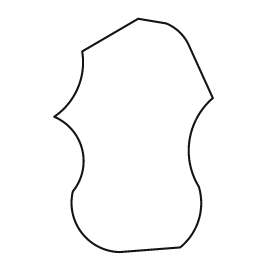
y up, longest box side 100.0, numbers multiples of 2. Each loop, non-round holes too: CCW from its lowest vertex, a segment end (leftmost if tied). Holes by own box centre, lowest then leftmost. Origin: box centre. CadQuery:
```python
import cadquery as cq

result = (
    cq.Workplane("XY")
    .moveTo(-6.0, -50.0)
    .lineTo(20.0, -48.0)
    .threePointArc((28.0, -36.0), (28.0, -22.0))
    .threePointArc((24.0, -2.0), (34.0, 16.0))
    .lineTo(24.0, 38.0)
    .threePointArc((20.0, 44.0), (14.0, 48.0))
    .lineTo(2.0, 50.0)
    .lineTo(-22.0, 36.0)
    .threePointArc((-24.0, 20.0), (-34.0, 8.0))
    .threePointArc((-22.0, -6.0), (-26.0, -24.0))
    .threePointArc((-22.0, -42.0), (-6.0, -50.0))
    .close()
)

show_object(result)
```